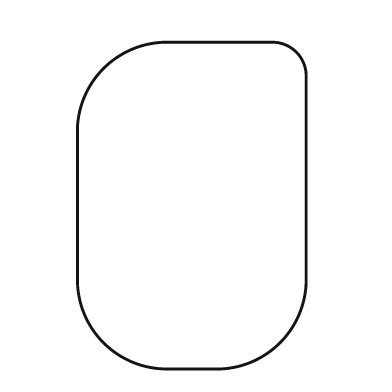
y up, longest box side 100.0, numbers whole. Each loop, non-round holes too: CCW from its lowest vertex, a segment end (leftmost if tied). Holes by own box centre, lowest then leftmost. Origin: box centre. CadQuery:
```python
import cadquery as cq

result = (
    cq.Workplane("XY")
    .moveTo(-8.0, -50.0)
    .lineTo(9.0, -50.0)
    .threePointArc((27.0, -42.0), (35.0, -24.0))
    .lineTo(35.0, 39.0)
    .threePointArc((32.0, 47.0), (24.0, 50.0))
    .lineTo(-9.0, 50.0)
    .threePointArc((-27.0, 42.0), (-35.0, 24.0))
    .lineTo(-35.0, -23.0)
    .threePointArc((-27.0, -42.0), (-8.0, -50.0))
    .close()
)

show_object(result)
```